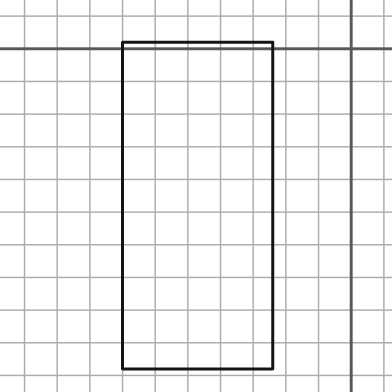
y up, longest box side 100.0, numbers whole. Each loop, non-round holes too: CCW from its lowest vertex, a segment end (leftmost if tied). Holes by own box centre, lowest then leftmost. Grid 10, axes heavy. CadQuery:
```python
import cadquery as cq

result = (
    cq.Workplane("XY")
    .moveTo(-70.0, -98.0)
    .lineTo(-24.0, -98.0)
    .lineTo(-24.0, 2.0)
    .lineTo(-70.0, 2.0)
    .close()
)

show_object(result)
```